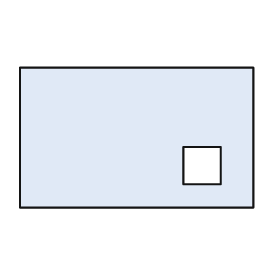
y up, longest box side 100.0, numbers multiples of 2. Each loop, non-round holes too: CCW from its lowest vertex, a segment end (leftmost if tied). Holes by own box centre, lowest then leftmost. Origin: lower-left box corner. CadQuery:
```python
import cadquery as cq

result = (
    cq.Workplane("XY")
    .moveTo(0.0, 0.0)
    .lineTo(100.0, 0.0)
    .lineTo(100.0, 60.0)
    .lineTo(0.0, 60.0)
    .close()
    .moveTo(70.0, 10.0)
    .lineTo(86.0, 10.0)
    .lineTo(86.0, 26.0)
    .lineTo(70.0, 26.0)
    .close()
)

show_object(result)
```